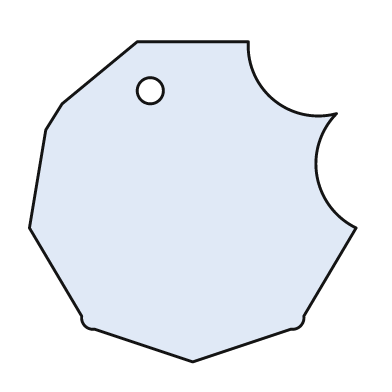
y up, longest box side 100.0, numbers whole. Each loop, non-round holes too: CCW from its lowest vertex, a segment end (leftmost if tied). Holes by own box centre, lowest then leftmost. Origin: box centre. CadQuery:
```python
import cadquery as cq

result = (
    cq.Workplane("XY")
    .moveTo(0.0, -49.0)
    .lineTo(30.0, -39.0)
    .threePointArc((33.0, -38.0), (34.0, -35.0))
    .lineTo(50.0, -8.0)
    .threePointArc((38.0, 8.0), (44.0, 27.0))
    .threePointArc((25.0, 31.0), (17.0, 49.0))
    .lineTo(-17.0, 49.0)
    .lineTo(-40.0, 30.0)
    .lineTo(-45.0, 22.0)
    .lineTo(-50.0, -8.0)
    .lineTo(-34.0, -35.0)
    .threePointArc((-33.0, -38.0), (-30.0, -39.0))
    .close()
    .moveTo(-13.0, 34.0)
    .circle(4.0)
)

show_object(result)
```